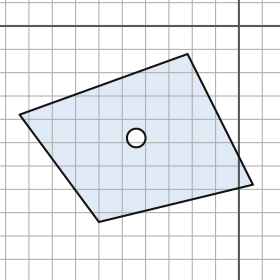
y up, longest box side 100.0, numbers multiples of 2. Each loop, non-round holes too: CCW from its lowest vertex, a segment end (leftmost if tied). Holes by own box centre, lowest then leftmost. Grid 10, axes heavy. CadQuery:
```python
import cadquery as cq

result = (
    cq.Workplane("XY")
    .moveTo(-60.0, -84.0)
    .lineTo(6.0, -68.0)
    .lineTo(-22.0, -12.0)
    .lineTo(-94.0, -38.0)
    .close()
    .moveTo(-44.0, -48.0)
    .circle(4.0)
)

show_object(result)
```